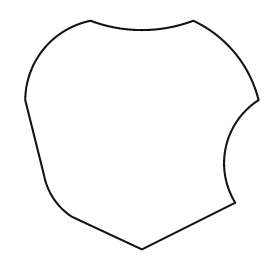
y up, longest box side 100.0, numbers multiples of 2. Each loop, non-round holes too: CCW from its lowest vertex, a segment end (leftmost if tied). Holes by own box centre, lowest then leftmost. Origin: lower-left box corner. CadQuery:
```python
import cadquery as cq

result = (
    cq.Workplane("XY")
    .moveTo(50.0, 0.0)
    .lineTo(90.0, 20.0)
    .threePointArc((86.0, 44.0), (100.0, 64.0))
    .threePointArc((90.0, 84.0), (72.0, 98.0))
    .threePointArc((50.0, 94.0), (28.0, 98.0))
    .threePointArc((8.0, 86.0), (0.0, 64.0))
    .lineTo(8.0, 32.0)
    .threePointArc((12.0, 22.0), (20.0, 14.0))
    .close()
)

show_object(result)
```